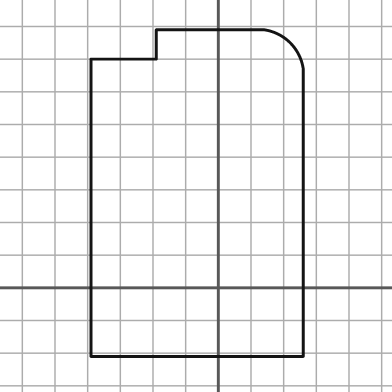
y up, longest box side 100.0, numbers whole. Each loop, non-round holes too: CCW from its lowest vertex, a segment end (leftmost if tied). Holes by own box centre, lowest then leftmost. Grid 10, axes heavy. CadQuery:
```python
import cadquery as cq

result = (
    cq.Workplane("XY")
    .moveTo(-39.0, -21.0)
    .lineTo(26.0, -21.0)
    .lineTo(26.0, 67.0)
    .threePointArc((22.0, 75.0), (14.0, 79.0))
    .lineTo(-19.0, 79.0)
    .lineTo(-19.0, 70.0)
    .lineTo(-39.0, 70.0)
    .close()
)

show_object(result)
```